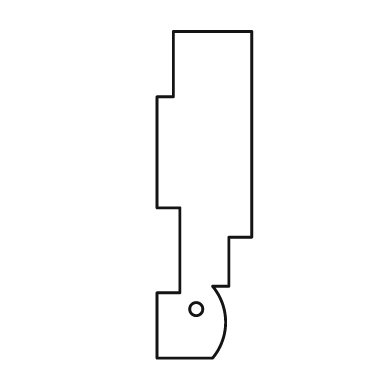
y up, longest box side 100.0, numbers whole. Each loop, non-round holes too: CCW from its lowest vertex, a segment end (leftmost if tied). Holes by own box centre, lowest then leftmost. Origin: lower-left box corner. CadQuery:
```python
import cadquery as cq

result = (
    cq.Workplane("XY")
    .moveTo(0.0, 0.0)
    .lineTo(17.0, 0.0)
    .threePointArc((21.0, 11.0), (17.0, 22.0))
    .lineTo(22.0, 22.0)
    .lineTo(22.0, 37.0)
    .lineTo(29.0, 37.0)
    .lineTo(29.0, 100.0)
    .lineTo(5.0, 100.0)
    .lineTo(5.0, 80.0)
    .lineTo(0.0, 80.0)
    .lineTo(0.0, 46.0)
    .lineTo(7.0, 46.0)
    .lineTo(7.0, 20.0)
    .lineTo(0.0, 20.0)
    .close()
    .moveTo(12.0, 15.0)
    .circle(2.0)
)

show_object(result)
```